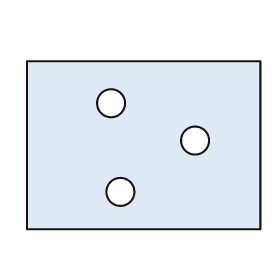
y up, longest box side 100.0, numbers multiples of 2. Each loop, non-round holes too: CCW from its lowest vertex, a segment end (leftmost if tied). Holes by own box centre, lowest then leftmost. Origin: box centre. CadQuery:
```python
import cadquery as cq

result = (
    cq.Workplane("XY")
    .moveTo(-50.0, -36.0)
    .lineTo(50.0, -36.0)
    .lineTo(50.0, 36.0)
    .lineTo(-50.0, 36.0)
    .close()
    .moveTo(-10.0, -20.0)
    .circle(6.0)
    .moveTo(22.0, 2.0)
    .circle(6.0)
    .moveTo(-14.0, 18.0)
    .circle(6.0)
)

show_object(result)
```